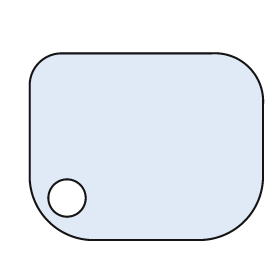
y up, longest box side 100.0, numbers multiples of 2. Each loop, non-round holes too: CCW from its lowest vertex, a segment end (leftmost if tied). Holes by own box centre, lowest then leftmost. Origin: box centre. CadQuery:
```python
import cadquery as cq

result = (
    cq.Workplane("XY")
    .moveTo(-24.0, -40.0)
    .lineTo(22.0, -40.0)
    .threePointArc((42.0, -32.0), (50.0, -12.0))
    .lineTo(50.0, 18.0)
    .threePointArc((44.0, 34.0), (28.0, 40.0))
    .lineTo(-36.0, 40.0)
    .threePointArc((-46.0, 36.0), (-50.0, 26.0))
    .lineTo(-50.0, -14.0)
    .threePointArc((-42.0, -32.0), (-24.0, -40.0))
    .close()
    .moveTo(-34.0, -22.0)
    .circle(8.0)
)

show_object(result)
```